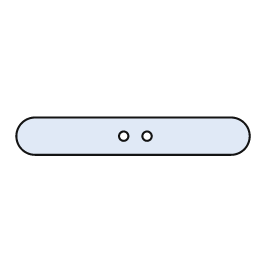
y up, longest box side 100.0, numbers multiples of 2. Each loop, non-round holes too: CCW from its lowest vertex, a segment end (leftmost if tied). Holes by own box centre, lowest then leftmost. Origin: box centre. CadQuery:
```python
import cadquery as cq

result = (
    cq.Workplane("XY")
    .moveTo(-42.0, -8.0)
    .lineTo(42.0, -8.0)
    .threePointArc((50.0, 0.0), (42.0, 8.0))
    .lineTo(-42.0, 8.0)
    .threePointArc((-50.0, 0.0), (-42.0, -8.0))
    .close()
    .moveTo(-4.0, 0.0)
    .circle(2.0)
    .moveTo(6.0, 0.0)
    .circle(2.0)
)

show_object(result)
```